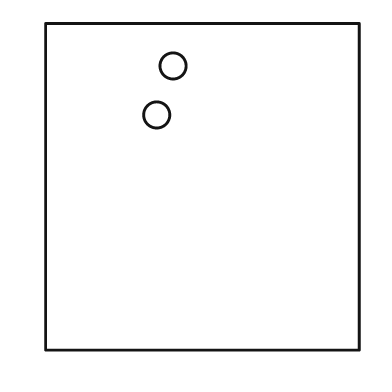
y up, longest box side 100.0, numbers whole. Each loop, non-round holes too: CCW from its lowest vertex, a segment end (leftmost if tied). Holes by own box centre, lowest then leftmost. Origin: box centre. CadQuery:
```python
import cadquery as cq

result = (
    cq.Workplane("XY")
    .moveTo(-48.0, -50.0)
    .lineTo(48.0, -50.0)
    .lineTo(48.0, 50.0)
    .lineTo(-48.0, 50.0)
    .close()
    .moveTo(-14.0, 22.0)
    .circle(4.0)
    .moveTo(-9.0, 37.0)
    .circle(4.0)
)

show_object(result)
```